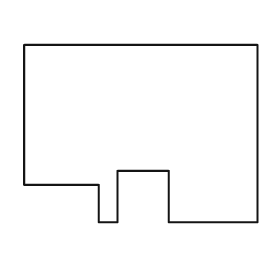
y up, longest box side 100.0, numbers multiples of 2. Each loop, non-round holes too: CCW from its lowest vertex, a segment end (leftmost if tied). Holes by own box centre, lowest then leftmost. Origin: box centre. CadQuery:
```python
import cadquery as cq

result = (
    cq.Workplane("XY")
    .moveTo(-18.0, -38.0)
    .lineTo(-10.0, -38.0)
    .lineTo(-10.0, -16.0)
    .lineTo(12.0, -16.0)
    .lineTo(12.0, -38.0)
    .lineTo(50.0, -38.0)
    .lineTo(50.0, 38.0)
    .lineTo(-50.0, 38.0)
    .lineTo(-50.0, -22.0)
    .lineTo(-18.0, -22.0)
    .close()
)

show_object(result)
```